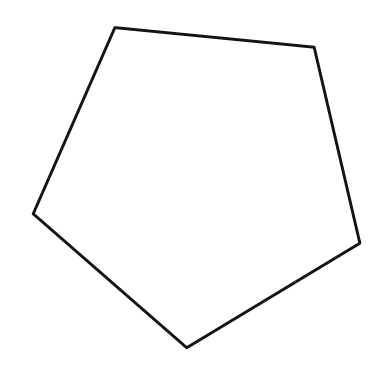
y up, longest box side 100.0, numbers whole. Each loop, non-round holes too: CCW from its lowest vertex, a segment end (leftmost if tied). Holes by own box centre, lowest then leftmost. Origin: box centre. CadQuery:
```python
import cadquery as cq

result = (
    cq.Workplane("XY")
    .moveTo(-3.0, -49.0)
    .lineTo(50.0, -17.0)
    .lineTo(36.0, 43.0)
    .lineTo(-25.0, 49.0)
    .lineTo(-50.0, -8.0)
    .close()
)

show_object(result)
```